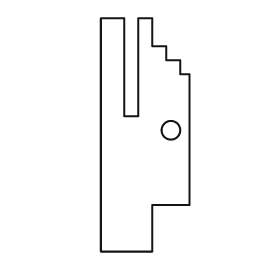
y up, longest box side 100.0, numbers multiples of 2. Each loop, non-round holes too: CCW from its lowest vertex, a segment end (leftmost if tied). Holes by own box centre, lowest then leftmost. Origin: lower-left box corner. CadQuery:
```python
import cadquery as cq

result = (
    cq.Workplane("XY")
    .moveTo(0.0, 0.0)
    .lineTo(22.0, 0.0)
    .lineTo(22.0, 20.0)
    .lineTo(38.0, 20.0)
    .lineTo(38.0, 76.0)
    .lineTo(34.0, 76.0)
    .lineTo(34.0, 82.0)
    .lineTo(28.0, 82.0)
    .lineTo(28.0, 88.0)
    .lineTo(22.0, 88.0)
    .lineTo(22.0, 100.0)
    .lineTo(16.0, 100.0)
    .lineTo(16.0, 58.0)
    .lineTo(10.0, 58.0)
    .lineTo(10.0, 100.0)
    .lineTo(0.0, 100.0)
    .close()
    .moveTo(30.0, 52.0)
    .circle(4.0)
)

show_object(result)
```